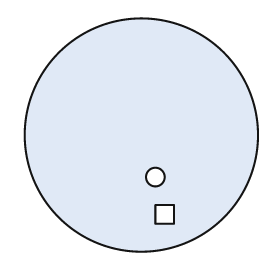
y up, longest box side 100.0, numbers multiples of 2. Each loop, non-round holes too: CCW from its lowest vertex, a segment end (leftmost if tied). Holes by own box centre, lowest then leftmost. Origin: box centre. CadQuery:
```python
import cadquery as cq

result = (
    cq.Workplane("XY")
    .moveTo(0.0, 0.0)
    .circle(50.0)
    .moveTo(6.0, -38.0)
    .lineTo(14.0, -38.0)
    .lineTo(14.0, -30.0)
    .lineTo(6.0, -30.0)
    .close()
    .moveTo(6.0, -18.0)
    .circle(4.0)
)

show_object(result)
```